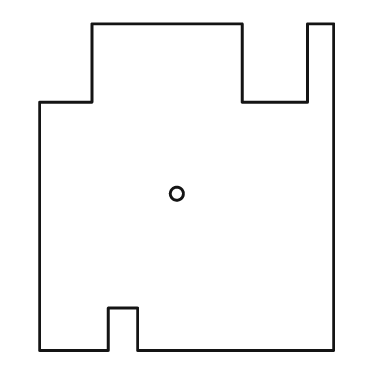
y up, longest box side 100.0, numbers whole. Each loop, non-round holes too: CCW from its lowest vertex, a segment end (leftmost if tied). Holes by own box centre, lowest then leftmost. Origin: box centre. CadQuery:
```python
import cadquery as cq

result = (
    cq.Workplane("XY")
    .moveTo(-45.0, -50.0)
    .lineTo(-24.0, -50.0)
    .lineTo(-24.0, -37.0)
    .lineTo(-15.0, -37.0)
    .lineTo(-15.0, -50.0)
    .lineTo(45.0, -50.0)
    .lineTo(45.0, 50.0)
    .lineTo(37.0, 50.0)
    .lineTo(37.0, 26.0)
    .lineTo(17.0, 26.0)
    .lineTo(17.0, 50.0)
    .lineTo(-29.0, 50.0)
    .lineTo(-29.0, 26.0)
    .lineTo(-45.0, 26.0)
    .close()
    .moveTo(-3.0, -2.0)
    .circle(2.0)
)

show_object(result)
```